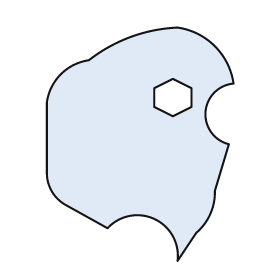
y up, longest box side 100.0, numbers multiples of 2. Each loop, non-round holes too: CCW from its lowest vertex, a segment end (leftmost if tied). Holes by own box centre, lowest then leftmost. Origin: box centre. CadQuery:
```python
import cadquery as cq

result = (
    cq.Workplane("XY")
    .moveTo(16.0, -50.0)
    .lineTo(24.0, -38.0)
    .threePointArc((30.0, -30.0), (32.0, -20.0))
    .lineTo(38.0, 0.0)
    .threePointArc((28.0, 14.0), (40.0, 26.0))
    .threePointArc((32.0, 42.0), (16.0, 50.0))
    .threePointArc((-4.0, 46.0), (-22.0, 36.0))
    .threePointArc((-34.0, 30.0), (-40.0, 18.0))
    .lineTo(-40.0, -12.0)
    .threePointArc((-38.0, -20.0), (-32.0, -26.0))
    .lineTo(-14.0, -36.0)
    .threePointArc((6.0, -32.0), (16.0, -50.0))
    .close()
    .moveTo(14.0, 12.0)
    .lineTo(22.0, 16.0)
    .lineTo(22.0, 24.0)
    .lineTo(14.0, 28.0)
    .lineTo(6.0, 24.0)
    .lineTo(6.0, 16.0)
    .close()
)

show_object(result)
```